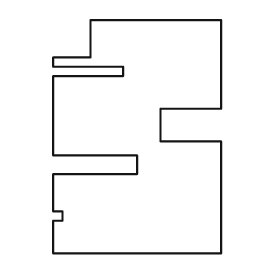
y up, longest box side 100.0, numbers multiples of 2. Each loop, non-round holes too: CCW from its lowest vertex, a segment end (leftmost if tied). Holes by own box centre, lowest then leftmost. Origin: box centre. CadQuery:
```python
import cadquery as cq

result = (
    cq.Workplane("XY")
    .moveTo(-36.0, -50.0)
    .lineTo(36.0, -50.0)
    .lineTo(36.0, -2.0)
    .lineTo(10.0, -2.0)
    .lineTo(10.0, 12.0)
    .lineTo(36.0, 12.0)
    .lineTo(36.0, 50.0)
    .lineTo(-20.0, 50.0)
    .lineTo(-20.0, 34.0)
    .lineTo(-36.0, 34.0)
    .lineTo(-36.0, 30.0)
    .lineTo(-6.0, 30.0)
    .lineTo(-6.0, 26.0)
    .lineTo(-36.0, 26.0)
    .lineTo(-36.0, -8.0)
    .lineTo(0.0, -8.0)
    .lineTo(0.0, -16.0)
    .lineTo(-36.0, -16.0)
    .lineTo(-36.0, -32.0)
    .lineTo(-32.0, -32.0)
    .lineTo(-32.0, -36.0)
    .lineTo(-36.0, -36.0)
    .close()
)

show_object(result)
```